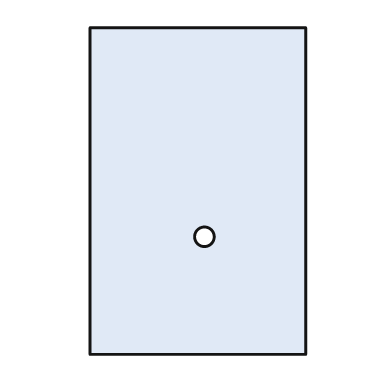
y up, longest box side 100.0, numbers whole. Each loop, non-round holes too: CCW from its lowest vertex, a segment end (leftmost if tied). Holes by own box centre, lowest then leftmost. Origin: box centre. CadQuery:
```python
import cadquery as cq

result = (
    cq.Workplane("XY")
    .moveTo(-33.0, -50.0)
    .lineTo(33.0, -50.0)
    .lineTo(33.0, 50.0)
    .lineTo(-33.0, 50.0)
    .close()
    .moveTo(2.0, -14.0)
    .circle(3.0)
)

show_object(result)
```